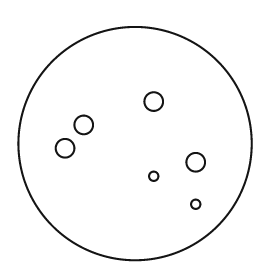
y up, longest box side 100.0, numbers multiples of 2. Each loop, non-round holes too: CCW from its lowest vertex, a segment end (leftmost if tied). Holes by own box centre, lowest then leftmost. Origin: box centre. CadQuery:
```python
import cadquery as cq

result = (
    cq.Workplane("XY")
    .moveTo(0.0, 0.0)
    .circle(50.0)
    .moveTo(26.0, -26.0)
    .circle(2.0)
    .moveTo(8.0, -14.0)
    .circle(2.0)
    .moveTo(26.0, -8.0)
    .circle(4.0)
    .moveTo(-30.0, -2.0)
    .circle(4.0)
    .moveTo(-22.0, 8.0)
    .circle(4.0)
    .moveTo(8.0, 18.0)
    .circle(4.0)
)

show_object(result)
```